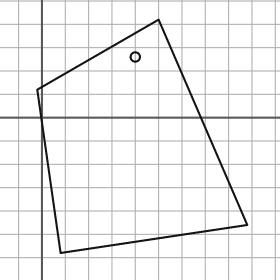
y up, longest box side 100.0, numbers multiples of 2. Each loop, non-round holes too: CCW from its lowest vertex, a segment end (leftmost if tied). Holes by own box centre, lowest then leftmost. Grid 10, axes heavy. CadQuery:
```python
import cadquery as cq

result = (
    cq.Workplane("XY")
    .moveTo(8.0, -58.0)
    .lineTo(88.0, -46.0)
    .lineTo(50.0, 42.0)
    .lineTo(-2.0, 12.0)
    .close()
    .moveTo(40.0, 26.0)
    .circle(2.0)
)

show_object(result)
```